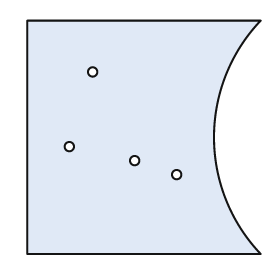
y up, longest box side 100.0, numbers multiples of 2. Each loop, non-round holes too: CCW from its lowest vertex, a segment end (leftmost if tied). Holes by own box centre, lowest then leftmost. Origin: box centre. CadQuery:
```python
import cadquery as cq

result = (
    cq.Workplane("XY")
    .moveTo(-50.0, -50.0)
    .lineTo(50.0, -50.0)
    .threePointArc((30.0, 0.0), (50.0, 50.0))
    .lineTo(-50.0, 50.0)
    .close()
    .moveTo(14.0, -16.0)
    .circle(2.0)
    .moveTo(-4.0, -10.0)
    .circle(2.0)
    .moveTo(-32.0, -4.0)
    .circle(2.0)
    .moveTo(-22.0, 28.0)
    .circle(2.0)
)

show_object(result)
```